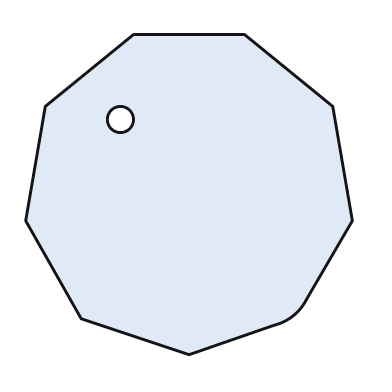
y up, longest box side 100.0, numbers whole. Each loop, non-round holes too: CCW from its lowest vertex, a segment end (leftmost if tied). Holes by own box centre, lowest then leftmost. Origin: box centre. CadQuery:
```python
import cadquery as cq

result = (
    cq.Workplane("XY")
    .moveTo(0.0, -49.0)
    .lineTo(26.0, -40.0)
    .threePointArc((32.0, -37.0), (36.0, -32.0))
    .lineTo(50.0, -8.0)
    .lineTo(44.0, 27.0)
    .lineTo(17.0, 49.0)
    .lineTo(-17.0, 49.0)
    .lineTo(-44.0, 27.0)
    .lineTo(-50.0, -8.0)
    .lineTo(-33.0, -38.0)
    .close()
    .moveTo(-21.0, 23.0)
    .circle(4.0)
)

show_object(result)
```